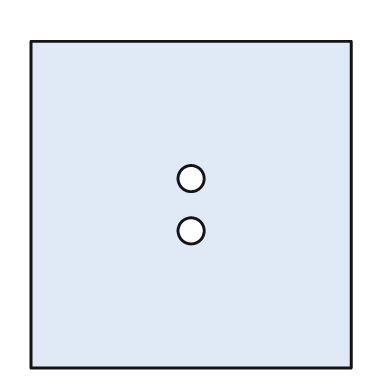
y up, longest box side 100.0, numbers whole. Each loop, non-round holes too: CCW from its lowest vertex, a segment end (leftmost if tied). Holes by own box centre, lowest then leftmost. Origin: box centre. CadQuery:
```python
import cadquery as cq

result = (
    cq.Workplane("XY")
    .moveTo(-49.0, -50.0)
    .lineTo(49.0, -50.0)
    .lineTo(49.0, 50.0)
    .lineTo(-49.0, 50.0)
    .close()
    .moveTo(0.0, -8.0)
    .circle(4.0)
    .moveTo(0.0, 8.0)
    .circle(4.0)
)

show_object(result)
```